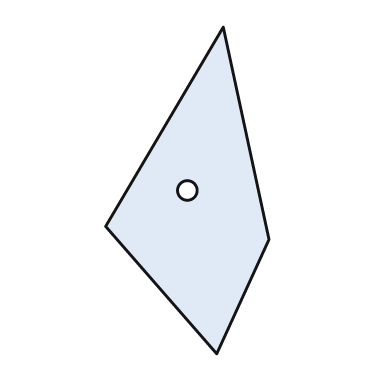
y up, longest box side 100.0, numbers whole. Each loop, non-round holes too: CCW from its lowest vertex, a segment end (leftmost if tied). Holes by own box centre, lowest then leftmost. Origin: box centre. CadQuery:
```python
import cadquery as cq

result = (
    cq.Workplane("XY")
    .moveTo(9.0, -50.0)
    .lineTo(25.0, -15.0)
    .lineTo(11.0, 50.0)
    .lineTo(-25.0, -11.0)
    .close()
    .moveTo(0.0, 0.0)
    .circle(3.0)
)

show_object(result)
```